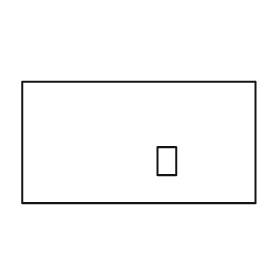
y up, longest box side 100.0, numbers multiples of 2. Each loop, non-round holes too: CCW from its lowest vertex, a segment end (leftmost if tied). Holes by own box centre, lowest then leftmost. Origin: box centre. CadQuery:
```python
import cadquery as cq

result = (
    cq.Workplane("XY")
    .moveTo(-50.0, -26.0)
    .lineTo(50.0, -26.0)
    .lineTo(50.0, 26.0)
    .lineTo(-50.0, 26.0)
    .close()
    .moveTo(8.0, -14.0)
    .lineTo(16.0, -14.0)
    .lineTo(16.0, -2.0)
    .lineTo(8.0, -2.0)
    .close()
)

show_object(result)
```